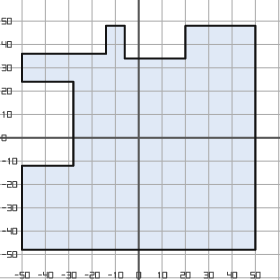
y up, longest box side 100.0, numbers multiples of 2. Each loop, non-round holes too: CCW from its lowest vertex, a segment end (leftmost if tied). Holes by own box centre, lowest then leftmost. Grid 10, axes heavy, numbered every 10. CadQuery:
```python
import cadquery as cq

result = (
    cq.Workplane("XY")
    .moveTo(-50.0, -48.0)
    .lineTo(50.0, -48.0)
    .lineTo(50.0, 48.0)
    .lineTo(20.0, 48.0)
    .lineTo(20.0, 34.0)
    .lineTo(-6.0, 34.0)
    .lineTo(-6.0, 48.0)
    .lineTo(-14.0, 48.0)
    .lineTo(-14.0, 36.0)
    .lineTo(-50.0, 36.0)
    .lineTo(-50.0, 24.0)
    .lineTo(-28.0, 24.0)
    .lineTo(-28.0, -12.0)
    .lineTo(-50.0, -12.0)
    .close()
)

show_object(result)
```